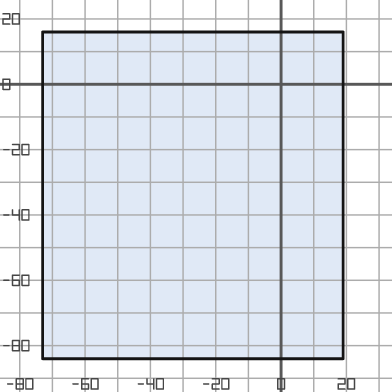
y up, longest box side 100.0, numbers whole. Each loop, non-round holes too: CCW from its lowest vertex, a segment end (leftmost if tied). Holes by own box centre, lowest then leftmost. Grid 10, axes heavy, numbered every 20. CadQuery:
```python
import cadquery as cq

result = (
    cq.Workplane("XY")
    .moveTo(-73.0, -84.0)
    .lineTo(19.0, -84.0)
    .lineTo(19.0, 16.0)
    .lineTo(-73.0, 16.0)
    .close()
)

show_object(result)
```